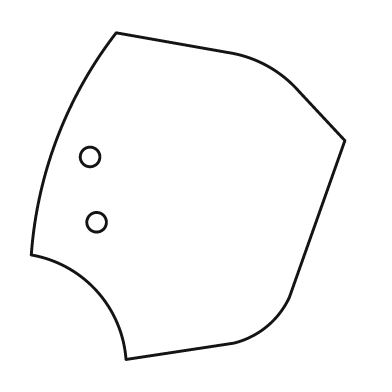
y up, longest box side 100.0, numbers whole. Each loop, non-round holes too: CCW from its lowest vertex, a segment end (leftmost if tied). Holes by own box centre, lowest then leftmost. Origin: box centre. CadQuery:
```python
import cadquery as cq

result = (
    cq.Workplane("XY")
    .moveTo(-19.0, -50.0)
    .lineTo(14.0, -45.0)
    .threePointArc((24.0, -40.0), (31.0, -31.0))
    .lineTo(48.0, 17.0)
    .lineTo(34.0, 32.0)
    .threePointArc((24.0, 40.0), (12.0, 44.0))
    .lineTo(-22.0, 50.0)
    .threePointArc((-40.0, 18.0), (-48.0, -18.0))
    .threePointArc((-28.0, -29.0), (-19.0, -50.0))
    .close()
    .moveTo(-28.0, -8.0)
    .circle(3.0)
    .moveTo(-30.0, 12.0)
    .circle(3.0)
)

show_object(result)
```